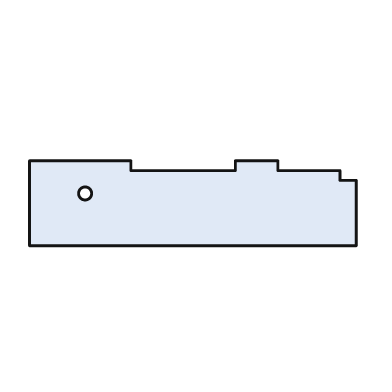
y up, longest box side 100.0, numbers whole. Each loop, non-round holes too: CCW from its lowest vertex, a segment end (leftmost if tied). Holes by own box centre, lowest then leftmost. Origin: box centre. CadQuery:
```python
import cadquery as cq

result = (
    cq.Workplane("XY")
    .moveTo(-50.0, -13.0)
    .lineTo(50.0, -13.0)
    .lineTo(50.0, 7.0)
    .lineTo(45.0, 7.0)
    .lineTo(45.0, 10.0)
    .lineTo(26.0, 10.0)
    .lineTo(26.0, 13.0)
    .lineTo(13.0, 13.0)
    .lineTo(13.0, 10.0)
    .lineTo(-19.0, 10.0)
    .lineTo(-19.0, 13.0)
    .lineTo(-50.0, 13.0)
    .close()
    .moveTo(-33.0, 3.0)
    .circle(2.0)
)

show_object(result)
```